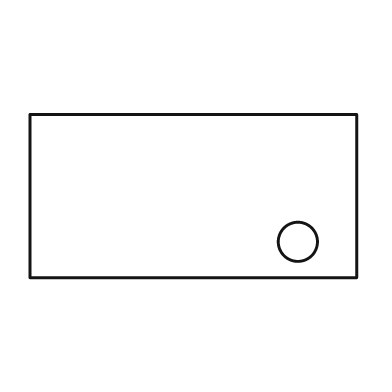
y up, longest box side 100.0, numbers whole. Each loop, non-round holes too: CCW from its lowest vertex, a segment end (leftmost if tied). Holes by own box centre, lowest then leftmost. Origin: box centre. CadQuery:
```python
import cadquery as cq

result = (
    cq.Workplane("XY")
    .moveTo(-50.0, -25.0)
    .lineTo(50.0, -25.0)
    .lineTo(50.0, 25.0)
    .lineTo(-50.0, 25.0)
    .close()
    .moveTo(32.0, -14.0)
    .circle(6.0)
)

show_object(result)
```